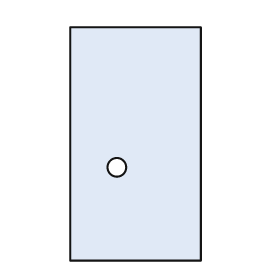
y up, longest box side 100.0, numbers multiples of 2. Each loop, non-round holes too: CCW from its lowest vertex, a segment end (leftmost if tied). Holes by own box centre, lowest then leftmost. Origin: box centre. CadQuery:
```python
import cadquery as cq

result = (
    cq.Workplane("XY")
    .moveTo(-28.0, -50.0)
    .lineTo(28.0, -50.0)
    .lineTo(28.0, 50.0)
    .lineTo(-28.0, 50.0)
    .close()
    .moveTo(-8.0, -10.0)
    .circle(4.0)
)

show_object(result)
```